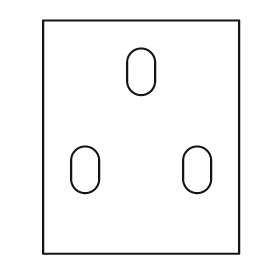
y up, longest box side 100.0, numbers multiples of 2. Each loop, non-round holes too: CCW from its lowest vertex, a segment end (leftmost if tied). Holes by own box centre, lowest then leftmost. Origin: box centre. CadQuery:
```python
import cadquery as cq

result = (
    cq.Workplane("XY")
    .moveTo(-42.0, -50.0)
    .lineTo(42.0, -50.0)
    .lineTo(42.0, 50.0)
    .lineTo(-42.0, 50.0)
    .close()
    .moveTo(-30.0, -18.0)
    .threePointArc((-24.0, -24.0), (-18.0, -18.0))
    .lineTo(-18.0, -10.0)
    .threePointArc((-24.0, -4.0), (-30.0, -10.0))
    .close()
    .moveTo(18.0, -18.0)
    .threePointArc((24.0, -24.0), (30.0, -18.0))
    .lineTo(30.0, -10.0)
    .threePointArc((24.0, -4.0), (18.0, -10.0))
    .close()
    .moveTo(-6.0, 24.0)
    .threePointArc((0.0, 18.0), (6.0, 24.0))
    .lineTo(6.0, 32.0)
    .threePointArc((0.0, 38.0), (-6.0, 32.0))
    .close()
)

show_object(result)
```